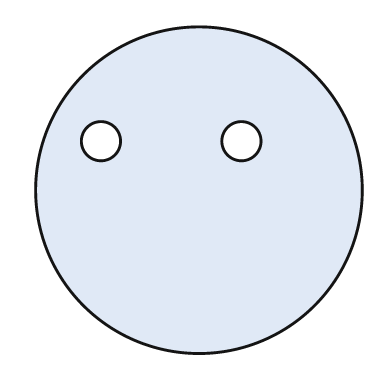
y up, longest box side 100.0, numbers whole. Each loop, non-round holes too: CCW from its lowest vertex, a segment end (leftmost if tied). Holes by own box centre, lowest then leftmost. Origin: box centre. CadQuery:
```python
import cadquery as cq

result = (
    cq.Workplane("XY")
    .moveTo(0.0, 0.0)
    .circle(50.0)
    .moveTo(-30.0, 15.0)
    .circle(6.0)
    .moveTo(13.0, 15.0)
    .circle(6.0)
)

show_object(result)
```